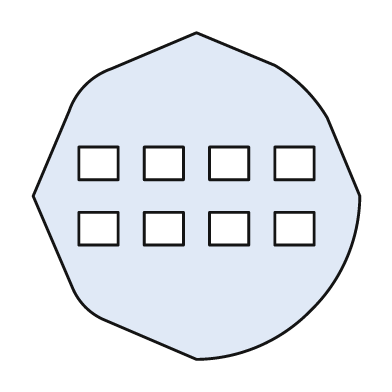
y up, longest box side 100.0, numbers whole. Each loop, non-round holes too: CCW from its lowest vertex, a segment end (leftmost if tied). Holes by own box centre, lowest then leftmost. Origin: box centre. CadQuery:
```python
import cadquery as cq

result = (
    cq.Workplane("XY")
    .moveTo(0.0, -50.0)
    .threePointArc((19.0, -46.0), (35.0, -35.0))
    .threePointArc((46.0, -19.0), (50.0, 0.0))
    .lineTo(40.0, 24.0)
    .threePointArc((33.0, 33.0), (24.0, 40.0))
    .lineTo(0.0, 50.0)
    .lineTo(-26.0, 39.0)
    .threePointArc((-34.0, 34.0), (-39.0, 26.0))
    .lineTo(-50.0, 0.0)
    .lineTo(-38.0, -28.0)
    .threePointArc((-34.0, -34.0), (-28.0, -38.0))
    .close()
    .moveTo(-36.0, -15.0)
    .lineTo(-24.0, -15.0)
    .lineTo(-24.0, -5.0)
    .lineTo(-36.0, -5.0)
    .close()
    .moveTo(-16.0, -15.0)
    .lineTo(-4.0, -15.0)
    .lineTo(-4.0, -5.0)
    .lineTo(-16.0, -5.0)
    .close()
    .moveTo(4.0, -15.0)
    .lineTo(16.0, -15.0)
    .lineTo(16.0, -5.0)
    .lineTo(4.0, -5.0)
    .close()
    .moveTo(24.0, -15.0)
    .lineTo(36.0, -15.0)
    .lineTo(36.0, -5.0)
    .lineTo(24.0, -5.0)
    .close()
    .moveTo(-36.0, 5.0)
    .lineTo(-24.0, 5.0)
    .lineTo(-24.0, 15.0)
    .lineTo(-36.0, 15.0)
    .close()
    .moveTo(-16.0, 5.0)
    .lineTo(-4.0, 5.0)
    .lineTo(-4.0, 15.0)
    .lineTo(-16.0, 15.0)
    .close()
    .moveTo(4.0, 5.0)
    .lineTo(16.0, 5.0)
    .lineTo(16.0, 15.0)
    .lineTo(4.0, 15.0)
    .close()
    .moveTo(24.0, 5.0)
    .lineTo(36.0, 5.0)
    .lineTo(36.0, 15.0)
    .lineTo(24.0, 15.0)
    .close()
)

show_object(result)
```